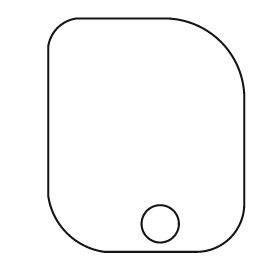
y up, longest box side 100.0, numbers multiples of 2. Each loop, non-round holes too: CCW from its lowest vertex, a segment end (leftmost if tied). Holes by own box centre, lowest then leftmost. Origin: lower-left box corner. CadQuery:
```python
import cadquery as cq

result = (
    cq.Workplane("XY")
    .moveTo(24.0, 0.0)
    .lineTo(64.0, 0.0)
    .threePointArc((78.0, 6.0), (84.0, 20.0))
    .lineTo(84.0, 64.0)
    .threePointArc((74.0, 90.0), (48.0, 100.0))
    .lineTo(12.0, 100.0)
    .threePointArc((4.0, 96.0), (0.0, 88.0))
    .lineTo(0.0, 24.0)
    .threePointArc((8.0, 8.0), (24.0, 0.0))
    .close()
    .moveTo(48.0, 12.0)
    .circle(8.0)
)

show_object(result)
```